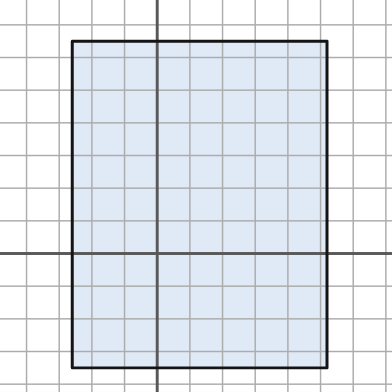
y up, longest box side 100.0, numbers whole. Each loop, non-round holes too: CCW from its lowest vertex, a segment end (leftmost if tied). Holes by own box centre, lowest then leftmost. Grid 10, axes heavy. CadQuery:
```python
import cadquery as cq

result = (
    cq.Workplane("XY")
    .moveTo(-26.0, -35.0)
    .lineTo(52.0, -35.0)
    .lineTo(52.0, 65.0)
    .lineTo(-26.0, 65.0)
    .close()
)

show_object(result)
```